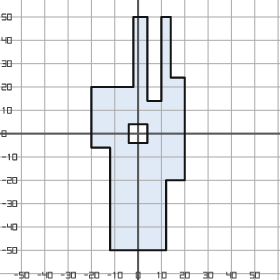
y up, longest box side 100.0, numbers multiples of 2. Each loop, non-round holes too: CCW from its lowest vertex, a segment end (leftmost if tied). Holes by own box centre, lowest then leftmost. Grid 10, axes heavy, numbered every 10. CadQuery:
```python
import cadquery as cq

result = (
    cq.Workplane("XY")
    .moveTo(-12.0, -50.0)
    .lineTo(12.0, -50.0)
    .lineTo(12.0, -20.0)
    .lineTo(20.0, -20.0)
    .lineTo(20.0, 24.0)
    .lineTo(14.0, 24.0)
    .lineTo(14.0, 50.0)
    .lineTo(10.0, 50.0)
    .lineTo(10.0, 14.0)
    .lineTo(4.0, 14.0)
    .lineTo(4.0, 50.0)
    .lineTo(-2.0, 50.0)
    .lineTo(-2.0, 20.0)
    .lineTo(-20.0, 20.0)
    .lineTo(-20.0, -6.0)
    .lineTo(-12.0, -6.0)
    .close()
    .moveTo(-4.0, -4.0)
    .lineTo(4.0, -4.0)
    .lineTo(4.0, 4.0)
    .lineTo(-4.0, 4.0)
    .close()
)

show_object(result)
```